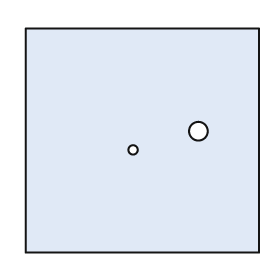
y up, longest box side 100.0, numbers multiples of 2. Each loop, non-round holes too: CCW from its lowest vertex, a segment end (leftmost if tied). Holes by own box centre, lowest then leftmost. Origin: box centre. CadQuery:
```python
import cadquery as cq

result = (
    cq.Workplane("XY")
    .moveTo(-50.0, -48.0)
    .lineTo(50.0, -48.0)
    .lineTo(50.0, 48.0)
    .lineTo(-50.0, 48.0)
    .close()
    .moveTo(-4.0, -4.0)
    .circle(2.0)
    .moveTo(24.0, 4.0)
    .circle(4.0)
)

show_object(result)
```